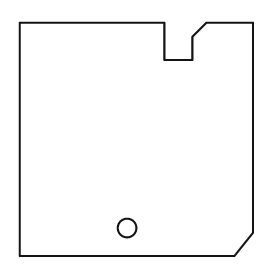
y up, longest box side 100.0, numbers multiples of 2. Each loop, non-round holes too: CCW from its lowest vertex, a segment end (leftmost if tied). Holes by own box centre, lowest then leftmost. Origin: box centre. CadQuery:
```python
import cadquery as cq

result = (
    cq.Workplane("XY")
    .moveTo(-50.0, -50.0)
    .lineTo(42.0, -50.0)
    .lineTo(50.0, -40.0)
    .lineTo(50.0, 50.0)
    .lineTo(30.0, 50.0)
    .lineTo(24.0, 44.0)
    .lineTo(24.0, 34.0)
    .lineTo(12.0, 34.0)
    .lineTo(12.0, 50.0)
    .lineTo(-50.0, 50.0)
    .close()
    .moveTo(-4.0, -38.0)
    .circle(4.0)
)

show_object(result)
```